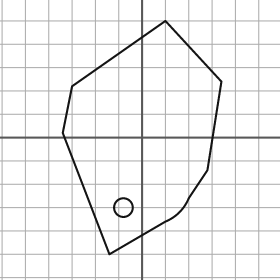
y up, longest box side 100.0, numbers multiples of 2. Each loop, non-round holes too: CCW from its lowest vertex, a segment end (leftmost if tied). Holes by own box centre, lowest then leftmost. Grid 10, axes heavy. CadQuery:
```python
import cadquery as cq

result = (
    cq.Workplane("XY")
    .moveTo(-14.0, -50.0)
    .lineTo(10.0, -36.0)
    .threePointArc((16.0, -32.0), (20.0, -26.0))
    .lineTo(28.0, -14.0)
    .lineTo(34.0, 24.0)
    .lineTo(10.0, 50.0)
    .lineTo(-30.0, 22.0)
    .lineTo(-34.0, 2.0)
    .close()
    .moveTo(-8.0, -30.0)
    .circle(4.0)
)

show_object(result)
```